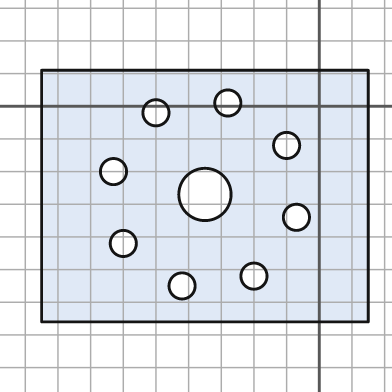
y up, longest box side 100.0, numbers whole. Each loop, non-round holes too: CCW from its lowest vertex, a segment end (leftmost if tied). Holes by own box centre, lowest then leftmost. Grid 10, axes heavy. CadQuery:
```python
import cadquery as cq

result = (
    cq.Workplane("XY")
    .moveTo(-85.0, -66.0)
    .lineTo(15.0, -66.0)
    .lineTo(15.0, 11.0)
    .lineTo(-85.0, 11.0)
    .close()
    .moveTo(-42.0, -55.0)
    .circle(4.0)
    .moveTo(-20.0, -52.0)
    .circle(4.0)
    .moveTo(-60.0, -42.0)
    .circle(4.0)
    .moveTo(-7.0, -34.0)
    .circle(4.0)
    .moveTo(-35.0, -27.0)
    .circle(8.0)
    .moveTo(-63.0, -20.0)
    .circle(4.0)
    .moveTo(-10.0, -12.0)
    .circle(4.0)
    .moveTo(-50.0, -2.0)
    .circle(4.0)
    .moveTo(-28.0, 1.0)
    .circle(4.0)
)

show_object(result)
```